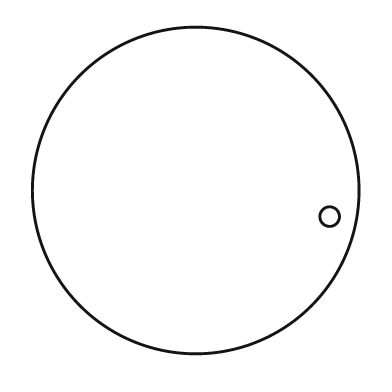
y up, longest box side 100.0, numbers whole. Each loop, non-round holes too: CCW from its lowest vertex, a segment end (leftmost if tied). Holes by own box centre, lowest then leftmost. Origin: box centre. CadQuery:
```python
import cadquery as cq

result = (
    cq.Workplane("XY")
    .moveTo(0.0, 0.0)
    .circle(50.0)
    .moveTo(41.0, -8.0)
    .circle(3.0)
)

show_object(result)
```